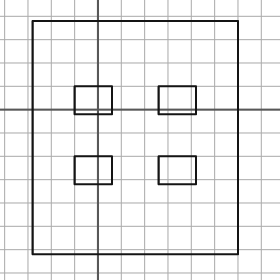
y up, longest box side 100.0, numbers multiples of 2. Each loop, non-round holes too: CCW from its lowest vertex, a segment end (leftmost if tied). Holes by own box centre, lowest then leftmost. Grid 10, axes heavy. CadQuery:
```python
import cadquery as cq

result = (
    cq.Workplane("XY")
    .moveTo(-28.0, -62.0)
    .lineTo(60.0, -62.0)
    .lineTo(60.0, 38.0)
    .lineTo(-28.0, 38.0)
    .close()
    .moveTo(-10.0, -32.0)
    .lineTo(6.0, -32.0)
    .lineTo(6.0, -20.0)
    .lineTo(-10.0, -20.0)
    .close()
    .moveTo(26.0, -32.0)
    .lineTo(42.0, -32.0)
    .lineTo(42.0, -20.0)
    .lineTo(26.0, -20.0)
    .close()
    .moveTo(-10.0, -2.0)
    .lineTo(6.0, -2.0)
    .lineTo(6.0, 10.0)
    .lineTo(-10.0, 10.0)
    .close()
    .moveTo(26.0, -2.0)
    .lineTo(42.0, -2.0)
    .lineTo(42.0, 10.0)
    .lineTo(26.0, 10.0)
    .close()
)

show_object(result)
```